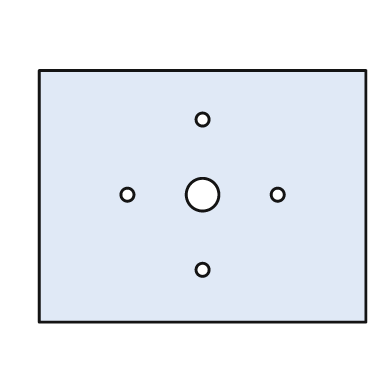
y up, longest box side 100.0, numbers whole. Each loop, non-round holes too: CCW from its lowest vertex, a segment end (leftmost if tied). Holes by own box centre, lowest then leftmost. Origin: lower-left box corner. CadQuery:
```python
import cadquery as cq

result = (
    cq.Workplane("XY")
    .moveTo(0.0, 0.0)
    .lineTo(100.0, 0.0)
    .lineTo(100.0, 77.0)
    .lineTo(0.0, 77.0)
    .close()
    .moveTo(50.0, 16.0)
    .circle(2.0)
    .moveTo(27.0, 39.0)
    .circle(2.0)
    .moveTo(50.0, 39.0)
    .circle(5.0)
    .moveTo(73.0, 39.0)
    .circle(2.0)
    .moveTo(50.0, 62.0)
    .circle(2.0)
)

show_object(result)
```